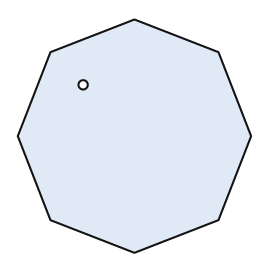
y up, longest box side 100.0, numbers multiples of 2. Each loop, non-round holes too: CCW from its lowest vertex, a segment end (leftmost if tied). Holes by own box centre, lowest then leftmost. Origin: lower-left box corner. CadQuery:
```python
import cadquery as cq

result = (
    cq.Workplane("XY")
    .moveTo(50.0, 0.0)
    .lineTo(86.0, 14.0)
    .lineTo(100.0, 50.0)
    .lineTo(86.0, 86.0)
    .lineTo(50.0, 100.0)
    .lineTo(14.0, 86.0)
    .lineTo(0.0, 50.0)
    .lineTo(14.0, 14.0)
    .close()
    .moveTo(28.0, 72.0)
    .circle(2.0)
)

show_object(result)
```